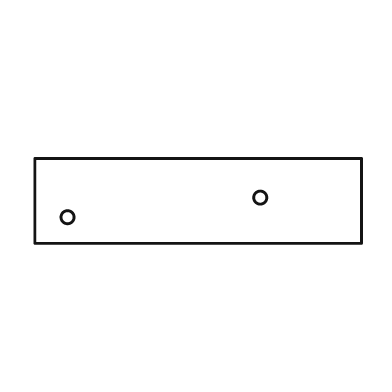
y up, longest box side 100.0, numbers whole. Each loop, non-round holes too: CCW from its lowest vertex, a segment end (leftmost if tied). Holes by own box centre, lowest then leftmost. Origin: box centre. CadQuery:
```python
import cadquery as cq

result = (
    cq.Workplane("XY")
    .moveTo(-50.0, -13.0)
    .lineTo(50.0, -13.0)
    .lineTo(50.0, 13.0)
    .lineTo(-50.0, 13.0)
    .close()
    .moveTo(-40.0, -5.0)
    .circle(2.0)
    .moveTo(19.0, 1.0)
    .circle(2.0)
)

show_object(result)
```